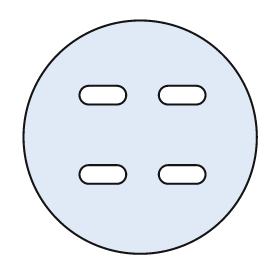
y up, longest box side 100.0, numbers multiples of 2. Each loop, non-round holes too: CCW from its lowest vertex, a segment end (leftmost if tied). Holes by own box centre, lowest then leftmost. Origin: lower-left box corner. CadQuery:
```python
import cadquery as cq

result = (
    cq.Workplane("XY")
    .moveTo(50.0, 50.0)
    .circle(50.0)
    .moveTo(28.0, 30.0)
    .lineTo(40.0, 30.0)
    .threePointArc((44.0, 34.0), (40.0, 38.0))
    .lineTo(28.0, 38.0)
    .threePointArc((24.0, 34.0), (28.0, 30.0))
    .close()
    .moveTo(62.0, 30.0)
    .lineTo(74.0, 30.0)
    .threePointArc((78.0, 34.0), (74.0, 38.0))
    .lineTo(62.0, 38.0)
    .threePointArc((58.0, 34.0), (62.0, 30.0))
    .close()
    .moveTo(28.0, 64.0)
    .lineTo(40.0, 64.0)
    .threePointArc((44.0, 68.0), (40.0, 72.0))
    .lineTo(28.0, 72.0)
    .threePointArc((24.0, 68.0), (28.0, 64.0))
    .close()
    .moveTo(62.0, 64.0)
    .lineTo(74.0, 64.0)
    .threePointArc((78.0, 68.0), (74.0, 72.0))
    .lineTo(62.0, 72.0)
    .threePointArc((58.0, 68.0), (62.0, 64.0))
    .close()
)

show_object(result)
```